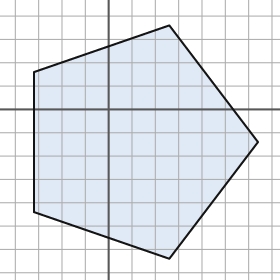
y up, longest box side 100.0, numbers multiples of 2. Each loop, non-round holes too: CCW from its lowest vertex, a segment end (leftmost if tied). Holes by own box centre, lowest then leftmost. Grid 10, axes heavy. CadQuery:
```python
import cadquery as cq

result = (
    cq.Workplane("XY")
    .moveTo(26.0, -64.0)
    .lineTo(64.0, -14.0)
    .lineTo(26.0, 36.0)
    .lineTo(-32.0, 16.0)
    .lineTo(-32.0, -44.0)
    .close()
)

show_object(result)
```